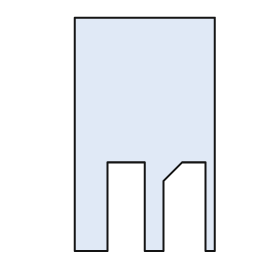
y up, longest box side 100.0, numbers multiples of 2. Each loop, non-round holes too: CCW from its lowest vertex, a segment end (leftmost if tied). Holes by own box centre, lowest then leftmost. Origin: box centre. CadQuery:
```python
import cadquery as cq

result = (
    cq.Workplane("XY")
    .moveTo(-30.0, -50.0)
    .lineTo(-16.0, -50.0)
    .lineTo(-16.0, -12.0)
    .lineTo(0.0, -12.0)
    .lineTo(0.0, -50.0)
    .lineTo(8.0, -50.0)
    .lineTo(8.0, -20.0)
    .lineTo(16.0, -12.0)
    .lineTo(26.0, -12.0)
    .lineTo(26.0, -50.0)
    .lineTo(30.0, -50.0)
    .lineTo(30.0, 50.0)
    .lineTo(-30.0, 50.0)
    .close()
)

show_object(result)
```